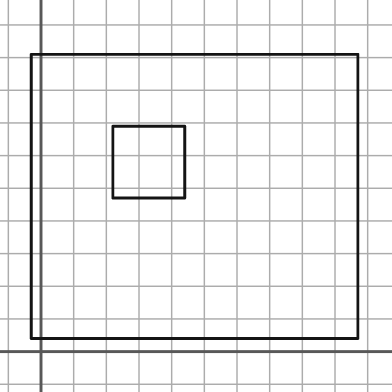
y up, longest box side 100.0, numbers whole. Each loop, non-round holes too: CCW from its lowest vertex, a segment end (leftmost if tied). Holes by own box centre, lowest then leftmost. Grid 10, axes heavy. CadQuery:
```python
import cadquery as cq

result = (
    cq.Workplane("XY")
    .moveTo(-3.0, 4.0)
    .lineTo(97.0, 4.0)
    .lineTo(97.0, 91.0)
    .lineTo(-3.0, 91.0)
    .close()
    .moveTo(22.0, 47.0)
    .lineTo(44.0, 47.0)
    .lineTo(44.0, 69.0)
    .lineTo(22.0, 69.0)
    .close()
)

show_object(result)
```